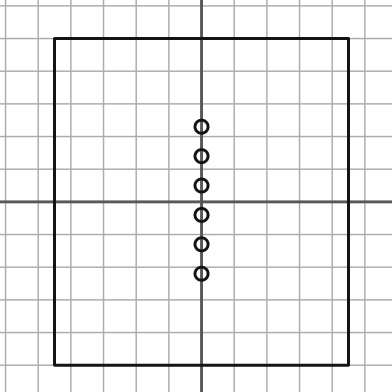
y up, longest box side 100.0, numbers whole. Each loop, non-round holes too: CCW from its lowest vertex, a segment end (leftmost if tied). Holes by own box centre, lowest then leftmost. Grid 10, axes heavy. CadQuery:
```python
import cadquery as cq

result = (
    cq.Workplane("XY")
    .moveTo(-45.0, -50.0)
    .lineTo(45.0, -50.0)
    .lineTo(45.0, 50.0)
    .lineTo(-45.0, 50.0)
    .close()
    .moveTo(0.0, -22.0)
    .circle(2.0)
    .moveTo(0.0, -13.0)
    .circle(2.0)
    .moveTo(0.0, -4.0)
    .circle(2.0)
    .moveTo(0.0, 5.0)
    .circle(2.0)
    .moveTo(0.0, 14.0)
    .circle(2.0)
    .moveTo(0.0, 23.0)
    .circle(2.0)
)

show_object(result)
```